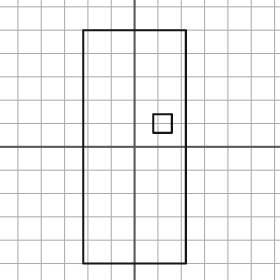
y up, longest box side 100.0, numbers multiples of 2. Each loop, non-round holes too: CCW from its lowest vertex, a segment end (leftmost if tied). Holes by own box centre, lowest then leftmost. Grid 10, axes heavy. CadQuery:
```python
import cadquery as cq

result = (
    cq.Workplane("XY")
    .moveTo(-22.0, -50.0)
    .lineTo(22.0, -50.0)
    .lineTo(22.0, 50.0)
    .lineTo(-22.0, 50.0)
    .close()
    .moveTo(8.0, 6.0)
    .lineTo(16.0, 6.0)
    .lineTo(16.0, 14.0)
    .lineTo(8.0, 14.0)
    .close()
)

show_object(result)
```